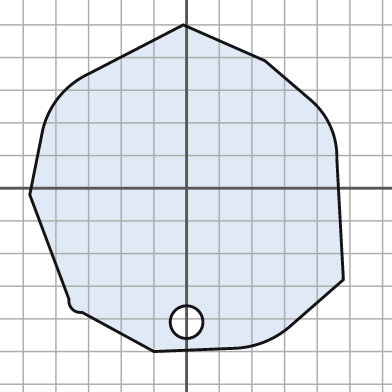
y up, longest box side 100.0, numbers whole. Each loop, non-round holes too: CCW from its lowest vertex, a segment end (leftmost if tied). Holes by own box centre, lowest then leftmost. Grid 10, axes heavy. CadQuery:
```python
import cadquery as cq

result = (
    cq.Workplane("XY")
    .moveTo(-10.0, -50.0)
    .lineTo(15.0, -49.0)
    .threePointArc((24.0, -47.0), (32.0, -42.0))
    .lineTo(48.0, -28.0)
    .lineTo(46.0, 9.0)
    .threePointArc((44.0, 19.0), (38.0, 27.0))
    .lineTo(24.0, 39.0)
    .lineTo(-1.0, 50.0)
    .lineTo(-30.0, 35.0)
    .threePointArc((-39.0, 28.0), (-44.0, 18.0))
    .lineTo(-48.0, -2.0)
    .lineTo(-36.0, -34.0)
    .threePointArc((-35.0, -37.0), (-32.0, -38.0))
    .close()
    .moveTo(0.0, -41.0)
    .circle(5.0)
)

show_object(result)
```